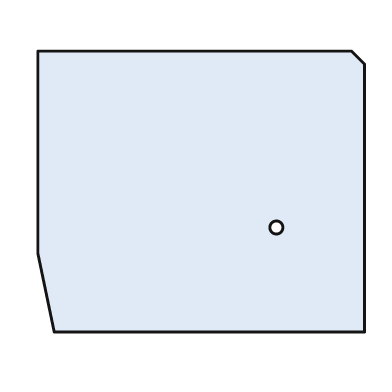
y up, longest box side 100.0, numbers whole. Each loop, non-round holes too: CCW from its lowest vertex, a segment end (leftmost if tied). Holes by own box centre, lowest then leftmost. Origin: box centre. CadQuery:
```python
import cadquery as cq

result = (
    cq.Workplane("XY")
    .moveTo(-45.0, -43.0)
    .lineTo(50.0, -43.0)
    .lineTo(50.0, 39.0)
    .lineTo(46.0, 43.0)
    .lineTo(-50.0, 43.0)
    .lineTo(-50.0, -19.0)
    .close()
    .moveTo(23.0, -11.0)
    .circle(2.0)
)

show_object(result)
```